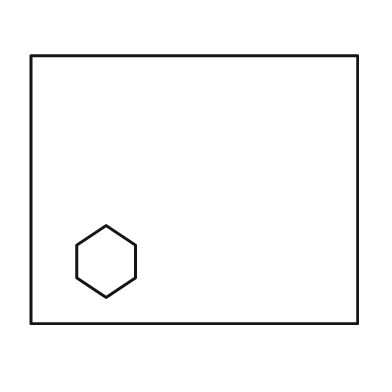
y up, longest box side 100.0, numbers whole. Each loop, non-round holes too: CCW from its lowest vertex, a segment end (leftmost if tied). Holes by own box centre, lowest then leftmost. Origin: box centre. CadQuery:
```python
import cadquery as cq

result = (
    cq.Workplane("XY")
    .moveTo(-50.0, -41.0)
    .lineTo(50.0, -41.0)
    .lineTo(50.0, 41.0)
    .lineTo(-50.0, 41.0)
    .close()
    .moveTo(-27.0, -33.0)
    .lineTo(-18.0, -27.0)
    .lineTo(-18.0, -17.0)
    .lineTo(-27.0, -11.0)
    .lineTo(-36.0, -17.0)
    .lineTo(-36.0, -27.0)
    .close()
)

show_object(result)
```